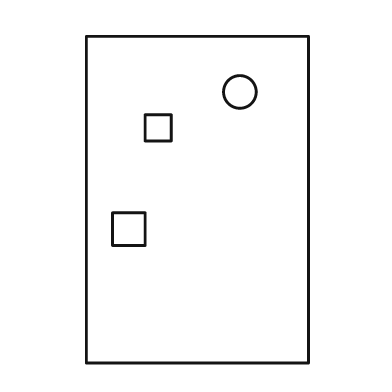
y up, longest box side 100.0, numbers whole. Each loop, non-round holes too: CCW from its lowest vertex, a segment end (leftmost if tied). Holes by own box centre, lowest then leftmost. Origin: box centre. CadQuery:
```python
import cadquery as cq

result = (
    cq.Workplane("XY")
    .moveTo(-34.0, -50.0)
    .lineTo(34.0, -50.0)
    .lineTo(34.0, 50.0)
    .lineTo(-34.0, 50.0)
    .close()
    .moveTo(-26.0, -14.0)
    .lineTo(-16.0, -14.0)
    .lineTo(-16.0, -4.0)
    .lineTo(-26.0, -4.0)
    .close()
    .moveTo(-16.0, 18.0)
    .lineTo(-8.0, 18.0)
    .lineTo(-8.0, 26.0)
    .lineTo(-16.0, 26.0)
    .close()
    .moveTo(13.0, 33.0)
    .circle(5.0)
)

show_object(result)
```